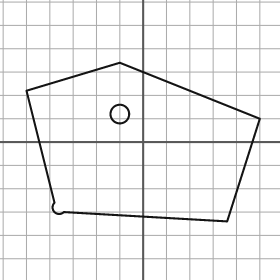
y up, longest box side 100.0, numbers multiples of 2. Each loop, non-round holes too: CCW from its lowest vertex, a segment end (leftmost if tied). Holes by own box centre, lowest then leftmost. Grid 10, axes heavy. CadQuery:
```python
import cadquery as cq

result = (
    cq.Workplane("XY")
    .moveTo(36.0, -34.0)
    .lineTo(50.0, 10.0)
    .lineTo(-10.0, 34.0)
    .lineTo(-50.0, 22.0)
    .lineTo(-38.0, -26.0)
    .threePointArc((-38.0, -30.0), (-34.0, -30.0))
    .close()
    .moveTo(-10.0, 12.0)
    .circle(4.0)
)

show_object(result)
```